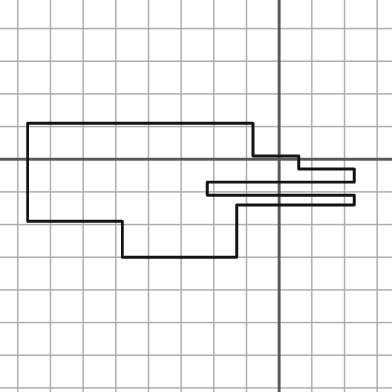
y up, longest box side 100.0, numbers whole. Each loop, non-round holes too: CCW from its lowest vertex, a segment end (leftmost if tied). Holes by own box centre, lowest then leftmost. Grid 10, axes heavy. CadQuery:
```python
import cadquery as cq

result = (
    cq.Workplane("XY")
    .moveTo(-48.0, -30.0)
    .lineTo(-13.0, -30.0)
    .lineTo(-13.0, -14.0)
    .lineTo(23.0, -14.0)
    .lineTo(23.0, -11.0)
    .lineTo(-22.0, -11.0)
    .lineTo(-22.0, -7.0)
    .lineTo(23.0, -7.0)
    .lineTo(23.0, -3.0)
    .lineTo(6.0, -3.0)
    .lineTo(6.0, 1.0)
    .lineTo(-8.0, 1.0)
    .lineTo(-8.0, 11.0)
    .lineTo(-77.0, 11.0)
    .lineTo(-77.0, -19.0)
    .lineTo(-48.0, -19.0)
    .close()
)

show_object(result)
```